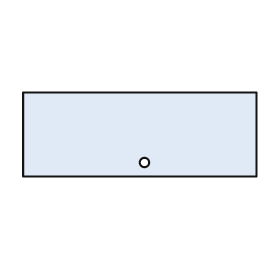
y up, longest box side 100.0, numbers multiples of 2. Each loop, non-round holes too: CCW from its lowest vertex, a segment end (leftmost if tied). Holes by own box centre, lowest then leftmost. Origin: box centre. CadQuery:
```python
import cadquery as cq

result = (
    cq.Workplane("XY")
    .moveTo(-50.0, -18.0)
    .lineTo(50.0, -18.0)
    .lineTo(50.0, 18.0)
    .lineTo(-50.0, 18.0)
    .close()
    .moveTo(2.0, -12.0)
    .circle(2.0)
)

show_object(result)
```